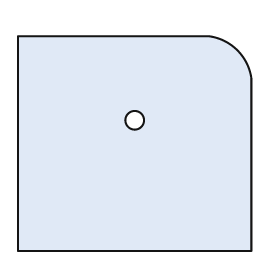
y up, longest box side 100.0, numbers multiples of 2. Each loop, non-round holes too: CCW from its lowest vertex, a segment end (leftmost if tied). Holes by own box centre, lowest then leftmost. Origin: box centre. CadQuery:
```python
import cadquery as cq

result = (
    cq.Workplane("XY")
    .moveTo(-50.0, -46.0)
    .lineTo(50.0, -46.0)
    .lineTo(50.0, 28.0)
    .threePointArc((44.0, 40.0), (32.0, 46.0))
    .lineTo(-50.0, 46.0)
    .close()
    .moveTo(0.0, 10.0)
    .circle(4.0)
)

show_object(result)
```